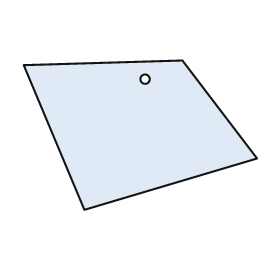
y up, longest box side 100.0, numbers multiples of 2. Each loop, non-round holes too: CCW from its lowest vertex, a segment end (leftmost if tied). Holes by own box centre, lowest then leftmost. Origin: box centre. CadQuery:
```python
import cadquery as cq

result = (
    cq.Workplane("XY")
    .moveTo(-24.0, -32.0)
    .lineTo(50.0, -10.0)
    .lineTo(18.0, 32.0)
    .lineTo(-50.0, 30.0)
    .close()
    .moveTo(2.0, 24.0)
    .circle(2.0)
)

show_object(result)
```